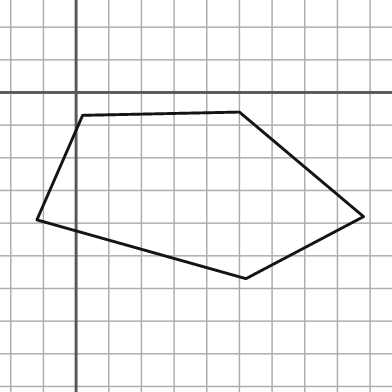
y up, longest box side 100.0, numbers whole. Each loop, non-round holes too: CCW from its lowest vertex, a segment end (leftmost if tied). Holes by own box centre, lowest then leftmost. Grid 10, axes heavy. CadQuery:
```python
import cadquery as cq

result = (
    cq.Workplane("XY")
    .moveTo(52.0, -57.0)
    .lineTo(88.0, -38.0)
    .lineTo(50.0, -6.0)
    .lineTo(2.0, -7.0)
    .lineTo(-12.0, -39.0)
    .close()
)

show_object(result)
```